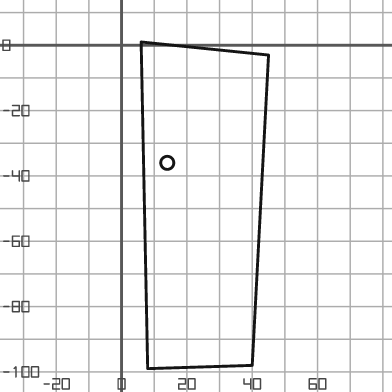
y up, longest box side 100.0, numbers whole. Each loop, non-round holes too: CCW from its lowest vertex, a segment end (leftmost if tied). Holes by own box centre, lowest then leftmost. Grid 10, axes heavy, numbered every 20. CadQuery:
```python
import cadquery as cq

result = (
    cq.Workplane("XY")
    .moveTo(8.0, -99.0)
    .lineTo(40.0, -98.0)
    .lineTo(45.0, -3.0)
    .lineTo(6.0, 1.0)
    .close()
    .moveTo(14.0, -36.0)
    .circle(2.0)
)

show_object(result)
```